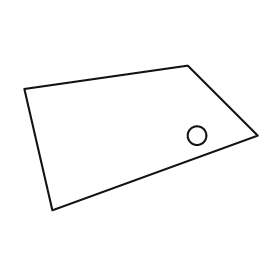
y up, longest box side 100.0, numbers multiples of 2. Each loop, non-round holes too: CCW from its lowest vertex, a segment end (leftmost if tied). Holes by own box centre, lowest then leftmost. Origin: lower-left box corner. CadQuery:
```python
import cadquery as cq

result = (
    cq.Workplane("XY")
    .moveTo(12.0, 0.0)
    .lineTo(100.0, 32.0)
    .lineTo(70.0, 62.0)
    .lineTo(0.0, 52.0)
    .close()
    .moveTo(74.0, 32.0)
    .circle(4.0)
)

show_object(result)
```